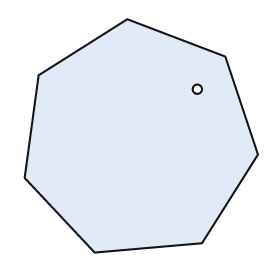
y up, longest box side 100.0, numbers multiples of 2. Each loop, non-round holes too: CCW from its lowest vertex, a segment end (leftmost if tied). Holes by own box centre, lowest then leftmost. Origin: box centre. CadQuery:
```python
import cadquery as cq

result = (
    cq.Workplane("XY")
    .moveTo(-20.0, -50.0)
    .lineTo(26.0, -46.0)
    .lineTo(50.0, -8.0)
    .lineTo(36.0, 34.0)
    .lineTo(-6.0, 50.0)
    .lineTo(-44.0, 26.0)
    .lineTo(-50.0, -18.0)
    .close()
    .moveTo(24.0, 20.0)
    .circle(2.0)
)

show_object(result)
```